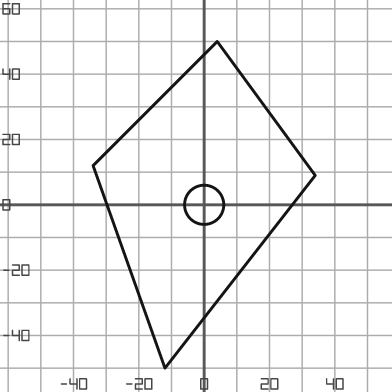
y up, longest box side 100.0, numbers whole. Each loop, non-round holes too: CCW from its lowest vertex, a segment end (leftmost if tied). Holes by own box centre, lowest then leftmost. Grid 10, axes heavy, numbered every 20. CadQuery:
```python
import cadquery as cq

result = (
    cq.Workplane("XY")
    .moveTo(-12.0, -50.0)
    .lineTo(34.0, 9.0)
    .lineTo(4.0, 50.0)
    .lineTo(-34.0, 12.0)
    .close()
    .moveTo(0.0, 0.0)
    .circle(6.0)
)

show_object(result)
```